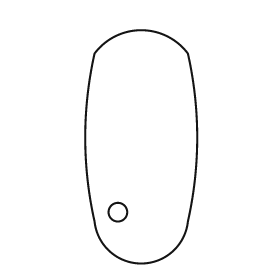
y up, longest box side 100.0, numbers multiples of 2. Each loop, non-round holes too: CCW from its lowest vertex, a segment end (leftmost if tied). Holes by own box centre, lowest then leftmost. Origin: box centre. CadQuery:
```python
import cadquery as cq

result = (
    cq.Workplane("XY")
    .moveTo(-20.0, -32.0)
    .threePointArc((0.0, -50.0), (20.0, -32.0))
    .threePointArc((24.0, 4.0), (20.0, 40.0))
    .threePointArc((0.0, 50.0), (-20.0, 40.0))
    .threePointArc((-24.0, 4.0), (-20.0, -32.0))
    .close()
    .moveTo(-10.0, -28.0)
    .circle(4.0)
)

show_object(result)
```